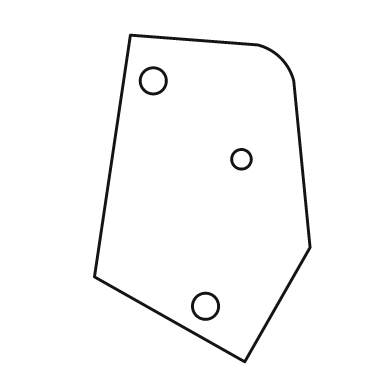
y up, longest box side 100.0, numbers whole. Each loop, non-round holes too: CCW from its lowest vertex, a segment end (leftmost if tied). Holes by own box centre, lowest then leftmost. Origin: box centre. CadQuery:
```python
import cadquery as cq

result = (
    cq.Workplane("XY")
    .moveTo(13.0, -50.0)
    .lineTo(33.0, -15.0)
    .lineTo(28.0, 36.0)
    .threePointArc((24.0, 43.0), (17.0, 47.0))
    .lineTo(-22.0, 50.0)
    .lineTo(-33.0, -24.0)
    .close()
    .moveTo(1.0, -33.0)
    .circle(4.0)
    .moveTo(12.0, 12.0)
    .circle(3.0)
    .moveTo(-15.0, 36.0)
    .circle(4.0)
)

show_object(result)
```